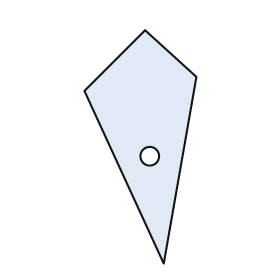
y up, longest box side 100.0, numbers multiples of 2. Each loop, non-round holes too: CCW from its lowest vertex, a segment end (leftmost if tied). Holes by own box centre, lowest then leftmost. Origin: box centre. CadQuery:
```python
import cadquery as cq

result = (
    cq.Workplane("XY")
    .moveTo(10.0, -50.0)
    .lineTo(24.0, 30.0)
    .lineTo(2.0, 50.0)
    .lineTo(-24.0, 24.0)
    .close()
    .moveTo(4.0, -4.0)
    .circle(4.0)
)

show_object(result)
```